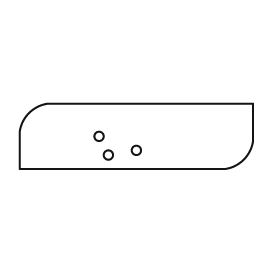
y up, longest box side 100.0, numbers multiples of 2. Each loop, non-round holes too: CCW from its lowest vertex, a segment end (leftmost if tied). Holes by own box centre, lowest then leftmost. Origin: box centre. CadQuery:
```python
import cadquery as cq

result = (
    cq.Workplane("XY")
    .moveTo(-50.0, -14.0)
    .lineTo(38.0, -14.0)
    .threePointArc((46.0, -10.0), (50.0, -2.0))
    .lineTo(50.0, 14.0)
    .lineTo(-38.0, 14.0)
    .threePointArc((-46.0, 10.0), (-50.0, 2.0))
    .close()
    .moveTo(-12.0, -8.0)
    .circle(2.0)
    .moveTo(0.0, -6.0)
    .circle(2.0)
    .moveTo(-16.0, 0.0)
    .circle(2.0)
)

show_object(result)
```